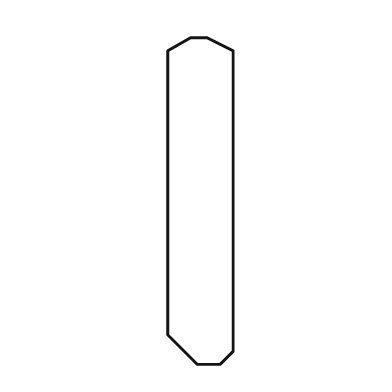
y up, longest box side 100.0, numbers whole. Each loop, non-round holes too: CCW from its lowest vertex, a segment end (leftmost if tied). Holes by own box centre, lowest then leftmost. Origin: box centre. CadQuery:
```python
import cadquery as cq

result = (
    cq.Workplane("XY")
    .moveTo(-1.0, -50.0)
    .lineTo(6.0, -50.0)
    .lineTo(10.0, -46.0)
    .lineTo(10.0, 46.0)
    .lineTo(2.0, 50.0)
    .lineTo(-3.0, 50.0)
    .lineTo(-10.0, 46.0)
    .lineTo(-10.0, -41.0)
    .close()
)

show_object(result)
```